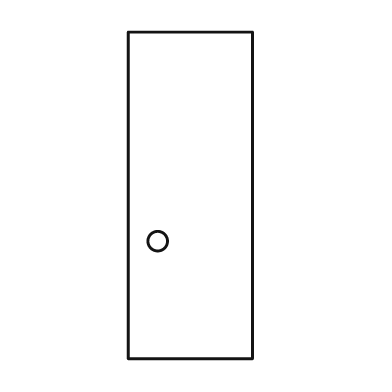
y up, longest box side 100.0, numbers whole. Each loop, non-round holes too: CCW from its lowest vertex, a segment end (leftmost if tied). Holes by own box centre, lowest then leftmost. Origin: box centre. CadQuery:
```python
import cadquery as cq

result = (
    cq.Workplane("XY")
    .moveTo(-19.0, -50.0)
    .lineTo(19.0, -50.0)
    .lineTo(19.0, 50.0)
    .lineTo(-19.0, 50.0)
    .close()
    .moveTo(-10.0, -14.0)
    .circle(3.0)
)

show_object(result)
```